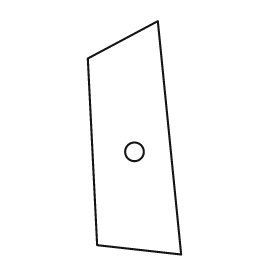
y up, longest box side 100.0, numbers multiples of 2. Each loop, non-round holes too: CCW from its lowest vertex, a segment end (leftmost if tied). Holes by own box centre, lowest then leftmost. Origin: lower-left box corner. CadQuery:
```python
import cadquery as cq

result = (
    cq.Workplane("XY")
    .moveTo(40.0, 0.0)
    .lineTo(30.0, 100.0)
    .lineTo(0.0, 84.0)
    .lineTo(4.0, 4.0)
    .close()
    .moveTo(20.0, 44.0)
    .circle(4.0)
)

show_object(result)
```